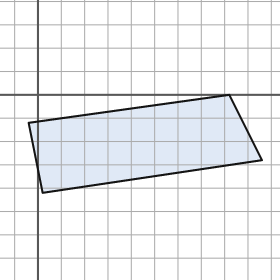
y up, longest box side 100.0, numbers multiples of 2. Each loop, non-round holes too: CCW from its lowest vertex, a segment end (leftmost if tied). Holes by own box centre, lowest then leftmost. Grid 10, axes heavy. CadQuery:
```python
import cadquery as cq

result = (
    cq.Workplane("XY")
    .moveTo(2.0, -42.0)
    .lineTo(96.0, -28.0)
    .lineTo(82.0, 0.0)
    .lineTo(-4.0, -12.0)
    .close()
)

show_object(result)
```